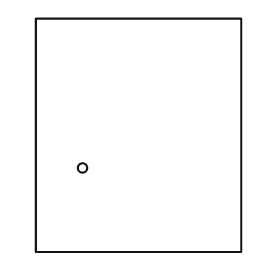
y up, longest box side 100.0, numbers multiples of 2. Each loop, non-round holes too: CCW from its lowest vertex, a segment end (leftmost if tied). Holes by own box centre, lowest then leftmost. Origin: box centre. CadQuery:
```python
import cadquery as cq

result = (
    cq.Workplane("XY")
    .moveTo(-44.0, -50.0)
    .lineTo(44.0, -50.0)
    .lineTo(44.0, 50.0)
    .lineTo(-44.0, 50.0)
    .close()
    .moveTo(-24.0, -14.0)
    .circle(2.0)
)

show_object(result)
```